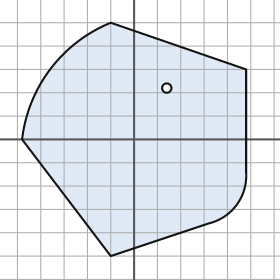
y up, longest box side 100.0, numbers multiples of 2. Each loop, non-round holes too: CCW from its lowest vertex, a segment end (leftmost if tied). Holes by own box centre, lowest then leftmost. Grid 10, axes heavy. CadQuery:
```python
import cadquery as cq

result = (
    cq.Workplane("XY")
    .moveTo(-10.0, -50.0)
    .lineTo(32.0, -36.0)
    .threePointArc((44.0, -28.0), (48.0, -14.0))
    .lineTo(48.0, 30.0)
    .lineTo(-10.0, 50.0)
    .threePointArc((-36.0, 30.0), (-48.0, 0.0))
    .close()
    .moveTo(14.0, 22.0)
    .circle(2.0)
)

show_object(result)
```